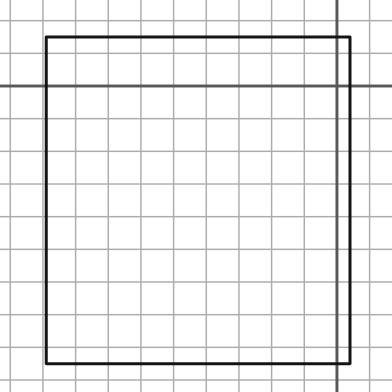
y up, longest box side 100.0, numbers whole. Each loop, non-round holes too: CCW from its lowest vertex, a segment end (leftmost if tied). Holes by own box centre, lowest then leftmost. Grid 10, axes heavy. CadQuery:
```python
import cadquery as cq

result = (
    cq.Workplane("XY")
    .moveTo(-89.0, -85.0)
    .lineTo(4.0, -85.0)
    .lineTo(4.0, 15.0)
    .lineTo(-89.0, 15.0)
    .close()
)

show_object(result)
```